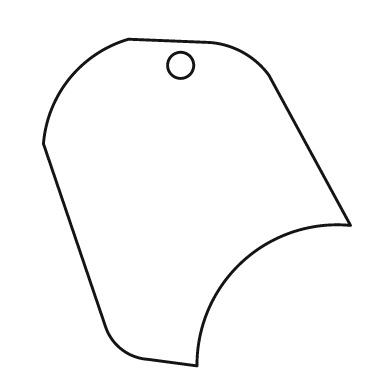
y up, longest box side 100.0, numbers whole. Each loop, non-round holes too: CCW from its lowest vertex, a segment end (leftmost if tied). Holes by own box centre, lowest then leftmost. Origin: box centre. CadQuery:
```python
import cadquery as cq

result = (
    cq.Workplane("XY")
    .moveTo(0.0, -50.0)
    .threePointArc((14.0, -18.0), (47.0, -7.0))
    .lineTo(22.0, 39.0)
    .threePointArc((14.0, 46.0), (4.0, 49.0))
    .lineTo(-21.0, 50.0)
    .threePointArc((-39.0, 38.0), (-47.0, 18.0))
    .lineTo(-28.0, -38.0)
    .threePointArc((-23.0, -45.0), (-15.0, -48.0))
    .close()
    .moveTo(-5.0, 42.0)
    .circle(4.0)
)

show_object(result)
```